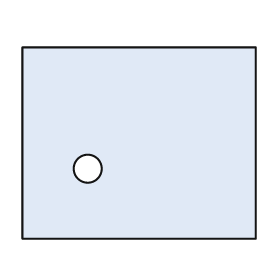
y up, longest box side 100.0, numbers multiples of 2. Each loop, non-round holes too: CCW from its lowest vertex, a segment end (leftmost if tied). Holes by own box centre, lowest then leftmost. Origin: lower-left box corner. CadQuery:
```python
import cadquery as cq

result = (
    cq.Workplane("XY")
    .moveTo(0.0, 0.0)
    .lineTo(100.0, 0.0)
    .lineTo(100.0, 82.0)
    .lineTo(0.0, 82.0)
    .close()
    .moveTo(28.0, 30.0)
    .circle(6.0)
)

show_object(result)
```